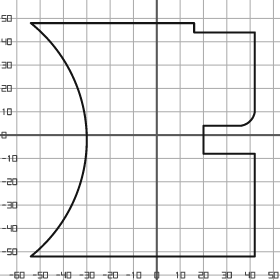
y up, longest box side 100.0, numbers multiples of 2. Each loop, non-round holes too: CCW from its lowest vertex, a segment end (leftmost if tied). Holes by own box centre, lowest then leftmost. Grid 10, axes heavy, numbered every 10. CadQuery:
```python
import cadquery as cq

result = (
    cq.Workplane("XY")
    .moveTo(-54.0, -52.0)
    .lineTo(42.0, -52.0)
    .lineTo(42.0, -8.0)
    .lineTo(20.0, -8.0)
    .lineTo(20.0, 4.0)
    .lineTo(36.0, 4.0)
    .threePointArc((40.0, 6.0), (42.0, 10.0))
    .lineTo(42.0, 44.0)
    .lineTo(16.0, 44.0)
    .lineTo(16.0, 48.0)
    .lineTo(-54.0, 48.0)
    .threePointArc((-30.0, -2.0), (-54.0, -52.0))
    .close()
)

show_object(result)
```